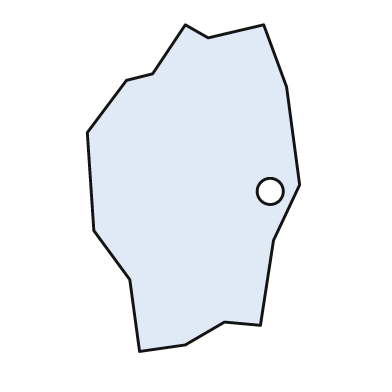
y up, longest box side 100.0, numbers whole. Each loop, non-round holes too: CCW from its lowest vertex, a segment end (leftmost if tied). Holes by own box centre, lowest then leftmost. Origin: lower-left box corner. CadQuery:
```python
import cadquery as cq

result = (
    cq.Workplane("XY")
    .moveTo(16.0, 0.0)
    .lineTo(30.0, 2.0)
    .lineTo(42.0, 9.0)
    .lineTo(53.0, 8.0)
    .lineTo(57.0, 34.0)
    .lineTo(65.0, 51.0)
    .lineTo(61.0, 81.0)
    .lineTo(54.0, 100.0)
    .lineTo(37.0, 96.0)
    .lineTo(30.0, 100.0)
    .lineTo(20.0, 85.0)
    .lineTo(12.0, 83.0)
    .lineTo(0.0, 67.0)
    .lineTo(2.0, 37.0)
    .lineTo(13.0, 22.0)
    .close()
    .moveTo(56.0, 49.0)
    .circle(4.0)
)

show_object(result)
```